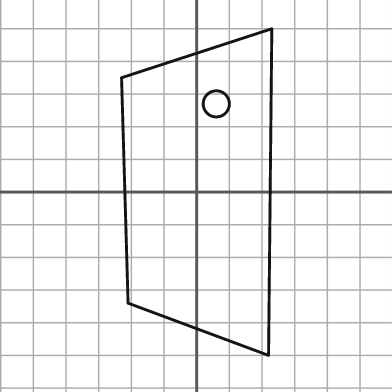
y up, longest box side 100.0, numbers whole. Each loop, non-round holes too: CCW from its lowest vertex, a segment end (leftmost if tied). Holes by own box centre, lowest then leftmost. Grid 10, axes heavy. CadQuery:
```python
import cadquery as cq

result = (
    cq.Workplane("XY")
    .moveTo(22.0, -50.0)
    .lineTo(23.0, 50.0)
    .lineTo(-23.0, 35.0)
    .lineTo(-21.0, -34.0)
    .close()
    .moveTo(6.0, 27.0)
    .circle(4.0)
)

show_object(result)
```